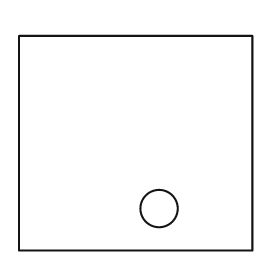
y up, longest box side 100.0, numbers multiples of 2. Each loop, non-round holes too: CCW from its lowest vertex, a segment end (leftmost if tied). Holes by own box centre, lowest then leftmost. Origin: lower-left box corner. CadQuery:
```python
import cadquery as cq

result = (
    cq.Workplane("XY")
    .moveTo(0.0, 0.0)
    .lineTo(100.0, 0.0)
    .lineTo(100.0, 92.0)
    .lineTo(0.0, 92.0)
    .close()
    .moveTo(60.0, 18.0)
    .circle(8.0)
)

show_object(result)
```